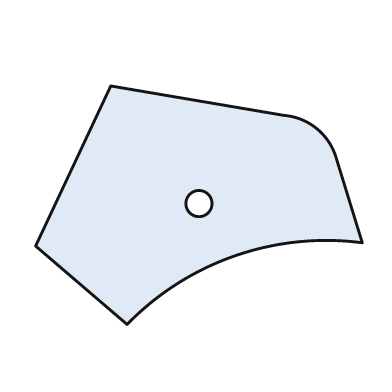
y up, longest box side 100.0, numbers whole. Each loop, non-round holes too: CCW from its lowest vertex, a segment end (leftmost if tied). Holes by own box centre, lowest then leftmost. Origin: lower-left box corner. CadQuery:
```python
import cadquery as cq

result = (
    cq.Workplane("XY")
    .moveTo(28.0, 0.0)
    .threePointArc((61.0, 21.0), (100.0, 25.0))
    .lineTo(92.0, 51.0)
    .threePointArc((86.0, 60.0), (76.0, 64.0))
    .lineTo(23.0, 73.0)
    .lineTo(0.0, 24.0)
    .close()
    .moveTo(50.0, 37.0)
    .circle(4.0)
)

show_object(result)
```